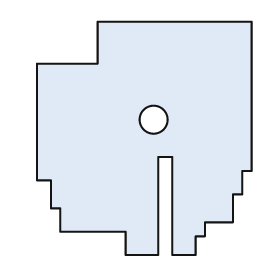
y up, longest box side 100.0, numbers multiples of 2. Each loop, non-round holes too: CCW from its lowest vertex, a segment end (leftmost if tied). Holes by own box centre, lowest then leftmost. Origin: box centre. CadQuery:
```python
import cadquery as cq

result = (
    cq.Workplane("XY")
    .moveTo(-8.0, -50.0)
    .lineTo(6.0, -50.0)
    .lineTo(6.0, -8.0)
    .lineTo(12.0, -8.0)
    .lineTo(12.0, -50.0)
    .lineTo(22.0, -50.0)
    .lineTo(22.0, -42.0)
    .lineTo(26.0, -42.0)
    .lineTo(26.0, -36.0)
    .lineTo(38.0, -36.0)
    .lineTo(38.0, -24.0)
    .lineTo(42.0, -24.0)
    .lineTo(42.0, -14.0)
    .lineTo(46.0, -14.0)
    .lineTo(46.0, 50.0)
    .lineTo(-20.0, 50.0)
    .lineTo(-20.0, 32.0)
    .lineTo(-46.0, 32.0)
    .lineTo(-46.0, -18.0)
    .lineTo(-40.0, -18.0)
    .lineTo(-40.0, -30.0)
    .lineTo(-36.0, -30.0)
    .lineTo(-36.0, -40.0)
    .lineTo(-8.0, -40.0)
    .close()
    .moveTo(4.0, 8.0)
    .circle(6.0)
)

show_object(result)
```